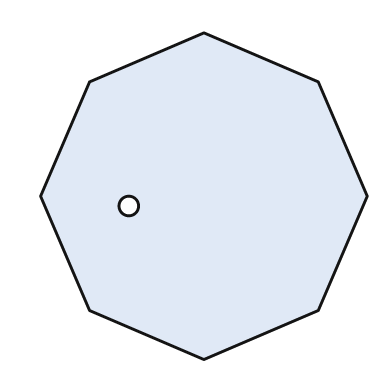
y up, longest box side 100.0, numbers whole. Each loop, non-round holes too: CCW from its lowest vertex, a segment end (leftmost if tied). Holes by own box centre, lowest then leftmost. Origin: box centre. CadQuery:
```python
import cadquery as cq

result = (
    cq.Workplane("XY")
    .moveTo(0.0, -50.0)
    .lineTo(35.0, -35.0)
    .lineTo(50.0, 0.0)
    .lineTo(35.0, 35.0)
    .lineTo(0.0, 50.0)
    .lineTo(-35.0, 35.0)
    .lineTo(-50.0, 0.0)
    .lineTo(-35.0, -35.0)
    .close()
    .moveTo(-23.0, -3.0)
    .circle(3.0)
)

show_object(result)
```